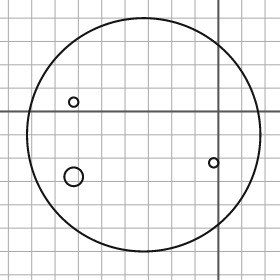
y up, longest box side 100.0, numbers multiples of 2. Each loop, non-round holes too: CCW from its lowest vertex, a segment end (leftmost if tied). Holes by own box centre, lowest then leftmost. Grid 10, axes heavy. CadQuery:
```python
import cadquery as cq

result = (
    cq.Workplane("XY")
    .moveTo(-32.0, -10.0)
    .circle(50.0)
    .moveTo(-62.0, -28.0)
    .circle(4.0)
    .moveTo(-2.0, -22.0)
    .circle(2.0)
    .moveTo(-62.0, 4.0)
    .circle(2.0)
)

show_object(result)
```